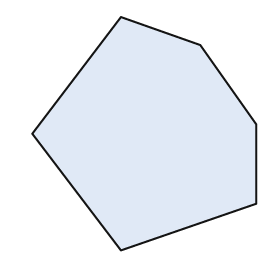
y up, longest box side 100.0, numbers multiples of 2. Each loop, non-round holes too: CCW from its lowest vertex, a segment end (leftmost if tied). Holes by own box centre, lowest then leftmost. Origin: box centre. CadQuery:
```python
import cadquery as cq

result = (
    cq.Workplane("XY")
    .moveTo(-10.0, -50.0)
    .lineTo(48.0, -30.0)
    .lineTo(48.0, 4.0)
    .lineTo(24.0, 38.0)
    .lineTo(-10.0, 50.0)
    .lineTo(-48.0, 0.0)
    .close()
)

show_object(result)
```